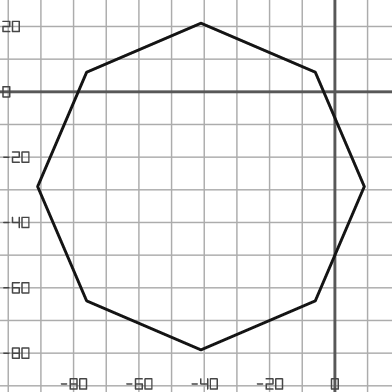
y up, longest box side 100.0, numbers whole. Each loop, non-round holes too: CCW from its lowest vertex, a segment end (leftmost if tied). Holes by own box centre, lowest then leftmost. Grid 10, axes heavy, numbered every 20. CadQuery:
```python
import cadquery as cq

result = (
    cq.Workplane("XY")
    .moveTo(-41.0, -79.0)
    .lineTo(-6.0, -64.0)
    .lineTo(9.0, -29.0)
    .lineTo(-6.0, 6.0)
    .lineTo(-41.0, 21.0)
    .lineTo(-76.0, 6.0)
    .lineTo(-91.0, -29.0)
    .lineTo(-76.0, -64.0)
    .close()
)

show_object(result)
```